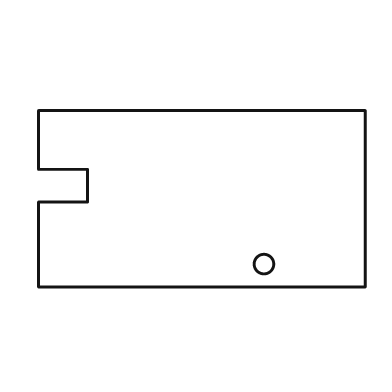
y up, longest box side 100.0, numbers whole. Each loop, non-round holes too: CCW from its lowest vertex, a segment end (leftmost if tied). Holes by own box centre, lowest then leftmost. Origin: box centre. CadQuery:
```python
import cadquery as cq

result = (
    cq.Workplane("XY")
    .moveTo(-50.0, -27.0)
    .lineTo(50.0, -27.0)
    .lineTo(50.0, 27.0)
    .lineTo(-50.0, 27.0)
    .lineTo(-50.0, 9.0)
    .lineTo(-35.0, 9.0)
    .lineTo(-35.0, -1.0)
    .lineTo(-50.0, -1.0)
    .close()
    .moveTo(19.0, -20.0)
    .circle(3.0)
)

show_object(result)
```